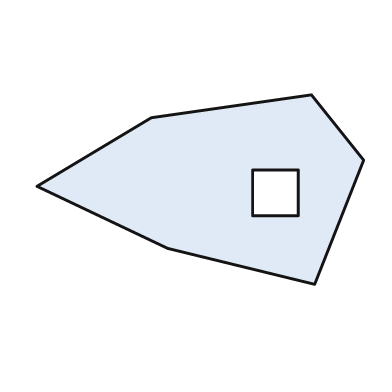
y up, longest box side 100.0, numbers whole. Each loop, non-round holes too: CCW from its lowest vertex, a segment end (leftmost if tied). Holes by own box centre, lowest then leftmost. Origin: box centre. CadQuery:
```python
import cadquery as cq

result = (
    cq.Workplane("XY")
    .moveTo(35.0, -29.0)
    .lineTo(50.0, 9.0)
    .lineTo(34.0, 29.0)
    .lineTo(-15.0, 22.0)
    .lineTo(-50.0, 1.0)
    .lineTo(-10.0, -18.0)
    .close()
    .moveTo(16.0, -8.0)
    .lineTo(30.0, -8.0)
    .lineTo(30.0, 6.0)
    .lineTo(16.0, 6.0)
    .close()
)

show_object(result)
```